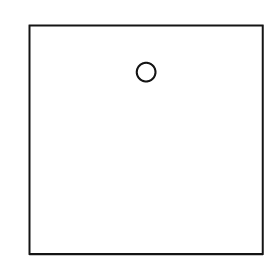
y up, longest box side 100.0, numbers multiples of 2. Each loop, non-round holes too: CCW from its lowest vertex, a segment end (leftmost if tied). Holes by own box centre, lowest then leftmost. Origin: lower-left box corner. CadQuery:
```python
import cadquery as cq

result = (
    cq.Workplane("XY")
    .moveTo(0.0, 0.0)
    .lineTo(100.0, 0.0)
    .lineTo(100.0, 98.0)
    .lineTo(0.0, 98.0)
    .close()
    .moveTo(50.0, 78.0)
    .circle(4.0)
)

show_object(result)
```